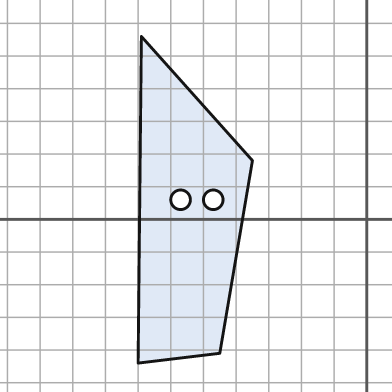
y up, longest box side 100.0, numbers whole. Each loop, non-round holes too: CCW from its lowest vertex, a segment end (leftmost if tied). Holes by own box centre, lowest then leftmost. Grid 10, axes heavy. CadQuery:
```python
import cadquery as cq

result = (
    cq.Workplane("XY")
    .moveTo(-70.0, -44.0)
    .lineTo(-45.0, -41.0)
    .lineTo(-35.0, 18.0)
    .lineTo(-69.0, 56.0)
    .close()
    .moveTo(-57.0, 6.0)
    .circle(3.0)
    .moveTo(-47.0, 6.0)
    .circle(3.0)
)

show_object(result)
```